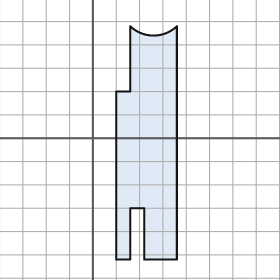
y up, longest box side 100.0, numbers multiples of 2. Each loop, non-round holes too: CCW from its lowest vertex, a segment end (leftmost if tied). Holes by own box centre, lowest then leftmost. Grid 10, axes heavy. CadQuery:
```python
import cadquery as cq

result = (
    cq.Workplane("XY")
    .moveTo(10.0, -52.0)
    .lineTo(16.0, -52.0)
    .lineTo(16.0, -30.0)
    .lineTo(22.0, -30.0)
    .lineTo(22.0, -52.0)
    .lineTo(36.0, -52.0)
    .lineTo(36.0, 48.0)
    .threePointArc((26.0, 44.0), (16.0, 48.0))
    .lineTo(16.0, 20.0)
    .lineTo(10.0, 20.0)
    .close()
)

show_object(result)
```